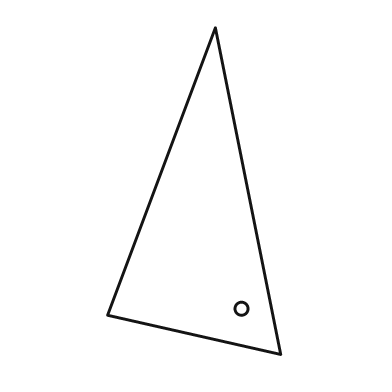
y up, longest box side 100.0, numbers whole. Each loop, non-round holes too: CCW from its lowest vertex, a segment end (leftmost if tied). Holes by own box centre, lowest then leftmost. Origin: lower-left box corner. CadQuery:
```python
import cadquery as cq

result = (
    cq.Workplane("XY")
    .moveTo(53.0, 0.0)
    .lineTo(33.0, 100.0)
    .lineTo(0.0, 12.0)
    .close()
    .moveTo(41.0, 14.0)
    .circle(2.0)
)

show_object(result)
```